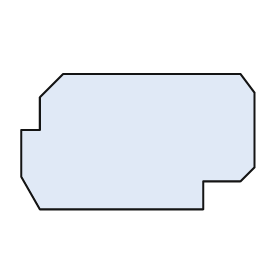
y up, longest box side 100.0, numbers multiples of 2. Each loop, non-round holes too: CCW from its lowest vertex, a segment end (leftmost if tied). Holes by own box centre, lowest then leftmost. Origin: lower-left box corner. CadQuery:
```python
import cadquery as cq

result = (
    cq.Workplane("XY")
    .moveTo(8.0, 0.0)
    .lineTo(78.0, 0.0)
    .lineTo(78.0, 12.0)
    .lineTo(94.0, 12.0)
    .lineTo(100.0, 18.0)
    .lineTo(100.0, 50.0)
    .lineTo(94.0, 58.0)
    .lineTo(18.0, 58.0)
    .lineTo(8.0, 48.0)
    .lineTo(8.0, 34.0)
    .lineTo(0.0, 34.0)
    .lineTo(0.0, 14.0)
    .close()
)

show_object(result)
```